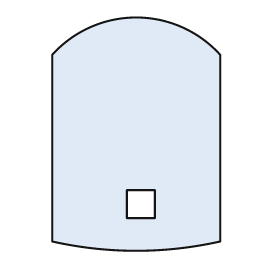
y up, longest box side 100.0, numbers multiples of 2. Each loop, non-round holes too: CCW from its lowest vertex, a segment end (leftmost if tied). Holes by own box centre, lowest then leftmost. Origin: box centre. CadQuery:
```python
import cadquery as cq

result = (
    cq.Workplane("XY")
    .moveTo(-36.0, -46.0)
    .threePointArc((0.0, -50.0), (36.0, -46.0))
    .lineTo(36.0, 34.0)
    .threePointArc((0.0, 50.0), (-36.0, 34.0))
    .close()
    .moveTo(-4.0, -36.0)
    .lineTo(8.0, -36.0)
    .lineTo(8.0, -24.0)
    .lineTo(-4.0, -24.0)
    .close()
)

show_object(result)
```